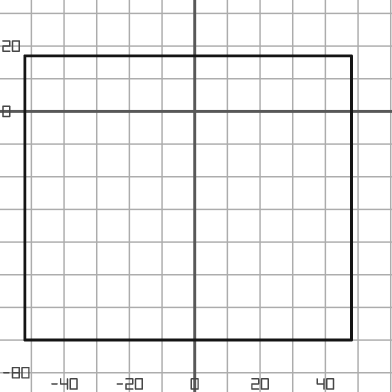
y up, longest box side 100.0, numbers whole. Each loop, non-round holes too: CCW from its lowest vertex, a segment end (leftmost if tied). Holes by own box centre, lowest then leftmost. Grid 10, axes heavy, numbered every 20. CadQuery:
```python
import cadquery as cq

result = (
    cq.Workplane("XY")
    .moveTo(-52.0, -70.0)
    .lineTo(48.0, -70.0)
    .lineTo(48.0, 17.0)
    .lineTo(-52.0, 17.0)
    .close()
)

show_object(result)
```